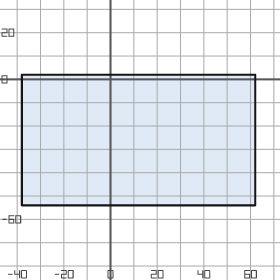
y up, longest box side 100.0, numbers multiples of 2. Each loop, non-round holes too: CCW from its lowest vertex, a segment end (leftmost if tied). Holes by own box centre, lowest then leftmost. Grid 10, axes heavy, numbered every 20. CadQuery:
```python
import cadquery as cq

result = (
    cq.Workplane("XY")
    .moveTo(-38.0, -54.0)
    .lineTo(62.0, -54.0)
    .lineTo(62.0, 2.0)
    .lineTo(-38.0, 2.0)
    .close()
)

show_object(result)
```